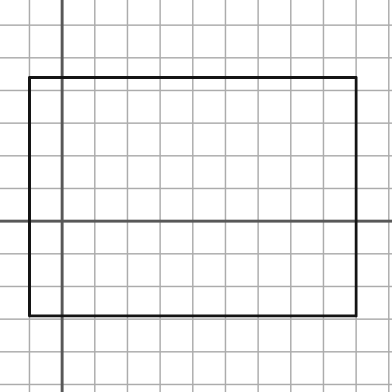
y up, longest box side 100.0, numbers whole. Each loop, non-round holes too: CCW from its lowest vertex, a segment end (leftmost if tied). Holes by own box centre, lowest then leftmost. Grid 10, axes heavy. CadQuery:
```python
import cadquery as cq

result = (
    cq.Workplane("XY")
    .moveTo(-10.0, -29.0)
    .lineTo(90.0, -29.0)
    .lineTo(90.0, 44.0)
    .lineTo(-10.0, 44.0)
    .close()
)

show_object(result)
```